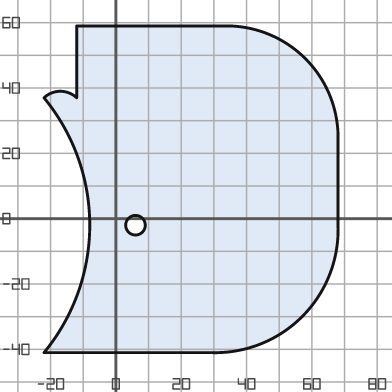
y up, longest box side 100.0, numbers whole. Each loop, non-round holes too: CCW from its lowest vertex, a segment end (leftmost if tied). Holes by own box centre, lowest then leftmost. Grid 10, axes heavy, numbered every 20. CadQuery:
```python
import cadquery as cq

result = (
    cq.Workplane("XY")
    .moveTo(-22.0, -41.0)
    .lineTo(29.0, -41.0)
    .threePointArc((57.0, -30.0), (68.0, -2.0))
    .lineTo(68.0, 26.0)
    .threePointArc((58.0, 49.0), (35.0, 59.0))
    .lineTo(-12.0, 59.0)
    .lineTo(-12.0, 37.0)
    .threePointArc((-17.0, 39.0), (-22.0, 37.0))
    .threePointArc((-8.0, -2.0), (-22.0, -41.0))
    .close()
    .moveTo(6.0, -2.0)
    .circle(3.0)
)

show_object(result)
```